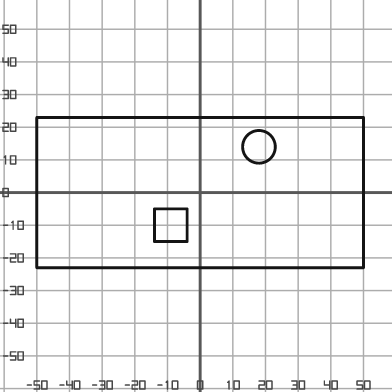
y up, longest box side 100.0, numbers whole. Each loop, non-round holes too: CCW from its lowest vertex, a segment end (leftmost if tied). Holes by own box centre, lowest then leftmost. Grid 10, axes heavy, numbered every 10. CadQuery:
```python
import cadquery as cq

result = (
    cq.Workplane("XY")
    .moveTo(-50.0, -23.0)
    .lineTo(50.0, -23.0)
    .lineTo(50.0, 23.0)
    .lineTo(-50.0, 23.0)
    .close()
    .moveTo(-14.0, -15.0)
    .lineTo(-4.0, -15.0)
    .lineTo(-4.0, -5.0)
    .lineTo(-14.0, -5.0)
    .close()
    .moveTo(18.0, 14.0)
    .circle(5.0)
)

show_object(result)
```